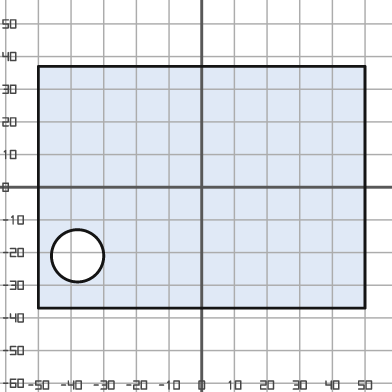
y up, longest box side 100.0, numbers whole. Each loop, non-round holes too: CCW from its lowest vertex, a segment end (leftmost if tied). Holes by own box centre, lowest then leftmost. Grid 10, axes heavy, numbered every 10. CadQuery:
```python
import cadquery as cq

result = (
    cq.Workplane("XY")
    .moveTo(-50.0, -37.0)
    .lineTo(50.0, -37.0)
    .lineTo(50.0, 37.0)
    .lineTo(-50.0, 37.0)
    .close()
    .moveTo(-38.0, -21.0)
    .circle(8.0)
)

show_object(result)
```